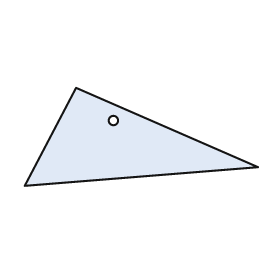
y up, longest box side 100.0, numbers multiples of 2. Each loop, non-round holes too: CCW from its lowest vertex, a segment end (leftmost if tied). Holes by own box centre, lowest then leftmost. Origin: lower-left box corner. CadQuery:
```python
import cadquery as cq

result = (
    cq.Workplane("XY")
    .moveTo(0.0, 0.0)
    .lineTo(100.0, 8.0)
    .lineTo(22.0, 42.0)
    .close()
    .moveTo(38.0, 28.0)
    .circle(2.0)
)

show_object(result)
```